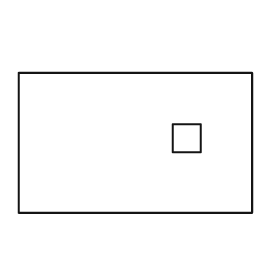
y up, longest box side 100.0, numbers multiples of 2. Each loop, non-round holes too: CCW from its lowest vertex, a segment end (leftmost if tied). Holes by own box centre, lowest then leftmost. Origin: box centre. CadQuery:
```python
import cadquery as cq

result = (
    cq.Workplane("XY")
    .moveTo(-50.0, -30.0)
    .lineTo(50.0, -30.0)
    .lineTo(50.0, 30.0)
    .lineTo(-50.0, 30.0)
    .close()
    .moveTo(16.0, -4.0)
    .lineTo(28.0, -4.0)
    .lineTo(28.0, 8.0)
    .lineTo(16.0, 8.0)
    .close()
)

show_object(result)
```